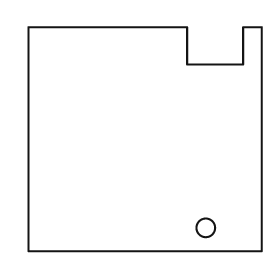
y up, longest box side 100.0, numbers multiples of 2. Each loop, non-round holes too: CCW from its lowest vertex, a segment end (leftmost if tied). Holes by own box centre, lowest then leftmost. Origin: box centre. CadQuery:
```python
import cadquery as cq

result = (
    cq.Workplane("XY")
    .moveTo(-50.0, -48.0)
    .lineTo(50.0, -48.0)
    .lineTo(50.0, 48.0)
    .lineTo(42.0, 48.0)
    .lineTo(42.0, 32.0)
    .lineTo(18.0, 32.0)
    .lineTo(18.0, 48.0)
    .lineTo(-50.0, 48.0)
    .close()
    .moveTo(26.0, -38.0)
    .circle(4.0)
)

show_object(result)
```